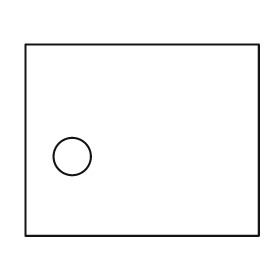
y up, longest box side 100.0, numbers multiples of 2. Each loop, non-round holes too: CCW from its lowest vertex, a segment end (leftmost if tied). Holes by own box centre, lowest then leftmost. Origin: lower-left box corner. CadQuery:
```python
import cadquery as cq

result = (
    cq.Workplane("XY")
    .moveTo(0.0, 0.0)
    .lineTo(100.0, 0.0)
    .lineTo(100.0, 82.0)
    .lineTo(0.0, 82.0)
    .close()
    .moveTo(20.0, 34.0)
    .circle(8.0)
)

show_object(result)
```